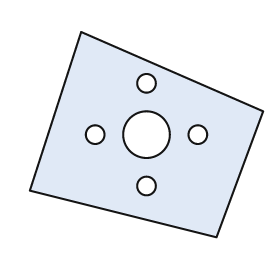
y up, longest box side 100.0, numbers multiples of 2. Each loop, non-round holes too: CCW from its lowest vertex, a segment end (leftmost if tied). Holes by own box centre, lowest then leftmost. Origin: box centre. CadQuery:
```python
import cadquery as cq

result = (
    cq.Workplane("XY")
    .moveTo(30.0, -44.0)
    .lineTo(50.0, 10.0)
    .lineTo(-28.0, 44.0)
    .lineTo(-50.0, -24.0)
    .close()
    .moveTo(0.0, -22.0)
    .circle(4.0)
    .moveTo(-22.0, 0.0)
    .circle(4.0)
    .moveTo(0.0, 0.0)
    .circle(10.0)
    .moveTo(22.0, 0.0)
    .circle(4.0)
    .moveTo(0.0, 22.0)
    .circle(4.0)
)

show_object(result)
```